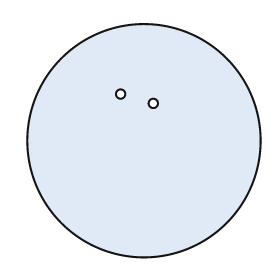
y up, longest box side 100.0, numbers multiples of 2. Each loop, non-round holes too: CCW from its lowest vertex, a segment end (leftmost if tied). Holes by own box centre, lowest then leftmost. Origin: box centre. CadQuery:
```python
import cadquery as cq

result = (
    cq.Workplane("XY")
    .moveTo(0.0, 0.0)
    .circle(50.0)
    .moveTo(4.0, 16.0)
    .circle(2.0)
    .moveTo(-10.0, 20.0)
    .circle(2.0)
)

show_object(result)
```